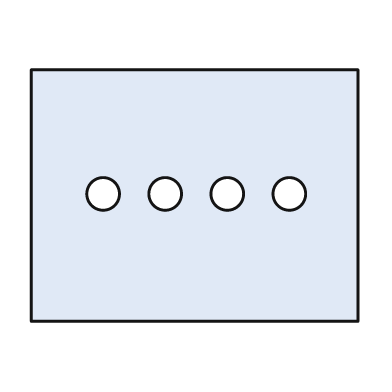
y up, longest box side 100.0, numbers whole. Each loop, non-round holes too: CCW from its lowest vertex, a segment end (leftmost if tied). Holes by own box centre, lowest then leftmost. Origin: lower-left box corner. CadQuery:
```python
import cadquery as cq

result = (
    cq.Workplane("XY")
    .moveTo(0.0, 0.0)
    .lineTo(100.0, 0.0)
    .lineTo(100.0, 77.0)
    .lineTo(0.0, 77.0)
    .close()
    .moveTo(22.0, 39.0)
    .circle(5.0)
    .moveTo(41.0, 39.0)
    .circle(5.0)
    .moveTo(60.0, 39.0)
    .circle(5.0)
    .moveTo(79.0, 39.0)
    .circle(5.0)
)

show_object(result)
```